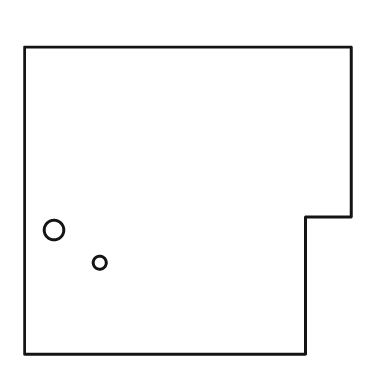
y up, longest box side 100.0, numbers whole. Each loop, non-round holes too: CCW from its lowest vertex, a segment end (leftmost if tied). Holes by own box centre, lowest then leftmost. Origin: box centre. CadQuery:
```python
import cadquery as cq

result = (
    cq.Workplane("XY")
    .moveTo(-50.0, -47.0)
    .lineTo(36.0, -47.0)
    .lineTo(36.0, -5.0)
    .lineTo(50.0, -5.0)
    .lineTo(50.0, 47.0)
    .lineTo(-50.0, 47.0)
    .close()
    .moveTo(-27.0, -19.0)
    .circle(2.0)
    .moveTo(-41.0, -9.0)
    .circle(3.0)
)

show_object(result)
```